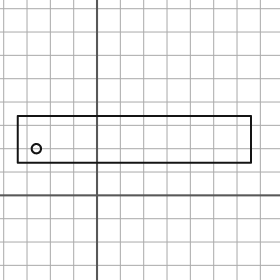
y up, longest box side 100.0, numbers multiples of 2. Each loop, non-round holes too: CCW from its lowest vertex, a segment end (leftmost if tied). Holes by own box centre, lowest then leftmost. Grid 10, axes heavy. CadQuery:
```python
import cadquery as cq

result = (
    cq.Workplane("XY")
    .moveTo(-34.0, 14.0)
    .lineTo(66.0, 14.0)
    .lineTo(66.0, 34.0)
    .lineTo(-34.0, 34.0)
    .close()
    .moveTo(-26.0, 20.0)
    .circle(2.0)
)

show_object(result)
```